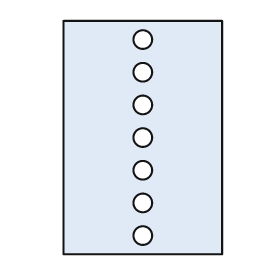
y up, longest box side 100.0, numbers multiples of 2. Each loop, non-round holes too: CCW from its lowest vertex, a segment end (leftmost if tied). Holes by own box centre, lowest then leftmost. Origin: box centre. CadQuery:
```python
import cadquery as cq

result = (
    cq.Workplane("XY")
    .moveTo(-34.0, -50.0)
    .lineTo(34.0, -50.0)
    .lineTo(34.0, 50.0)
    .lineTo(-34.0, 50.0)
    .close()
    .moveTo(0.0, -42.0)
    .circle(4.0)
    .moveTo(0.0, -28.0)
    .circle(4.0)
    .moveTo(0.0, -14.0)
    .circle(4.0)
    .moveTo(0.0, 0.0)
    .circle(4.0)
    .moveTo(0.0, 14.0)
    .circle(4.0)
    .moveTo(0.0, 28.0)
    .circle(4.0)
    .moveTo(0.0, 42.0)
    .circle(4.0)
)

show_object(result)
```